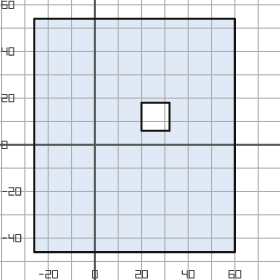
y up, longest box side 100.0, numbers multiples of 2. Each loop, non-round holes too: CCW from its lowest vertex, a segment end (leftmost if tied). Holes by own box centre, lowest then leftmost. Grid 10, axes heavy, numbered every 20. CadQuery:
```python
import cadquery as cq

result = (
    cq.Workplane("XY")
    .moveTo(-26.0, -46.0)
    .lineTo(60.0, -46.0)
    .lineTo(60.0, 54.0)
    .lineTo(-26.0, 54.0)
    .close()
    .moveTo(20.0, 6.0)
    .lineTo(32.0, 6.0)
    .lineTo(32.0, 18.0)
    .lineTo(20.0, 18.0)
    .close()
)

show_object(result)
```